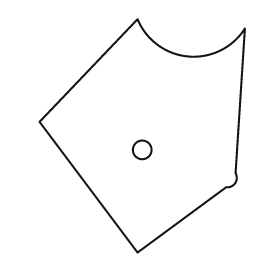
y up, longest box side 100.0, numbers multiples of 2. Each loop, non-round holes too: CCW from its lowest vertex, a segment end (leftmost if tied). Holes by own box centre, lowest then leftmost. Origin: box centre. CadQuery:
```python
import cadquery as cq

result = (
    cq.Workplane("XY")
    .moveTo(-2.0, -50.0)
    .lineTo(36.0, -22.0)
    .threePointArc((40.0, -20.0), (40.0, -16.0))
    .lineTo(44.0, 46.0)
    .threePointArc((20.0, 34.0), (-2.0, 50.0))
    .lineTo(-44.0, 6.0)
    .close()
    .moveTo(0.0, -6.0)
    .circle(4.0)
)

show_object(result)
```